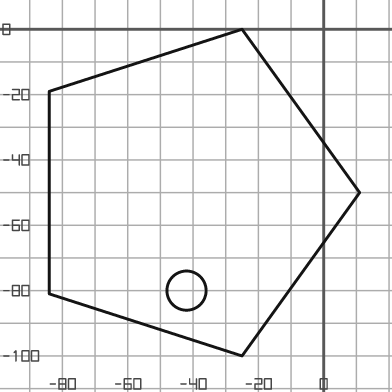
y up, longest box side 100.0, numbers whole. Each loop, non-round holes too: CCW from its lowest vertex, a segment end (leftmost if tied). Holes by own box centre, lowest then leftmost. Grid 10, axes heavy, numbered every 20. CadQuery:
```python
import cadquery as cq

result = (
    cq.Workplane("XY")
    .moveTo(-25.0, -100.0)
    .lineTo(11.0, -50.0)
    .lineTo(-25.0, 0.0)
    .lineTo(-84.0, -19.0)
    .lineTo(-84.0, -81.0)
    .close()
    .moveTo(-42.0, -80.0)
    .circle(6.0)
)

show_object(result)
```